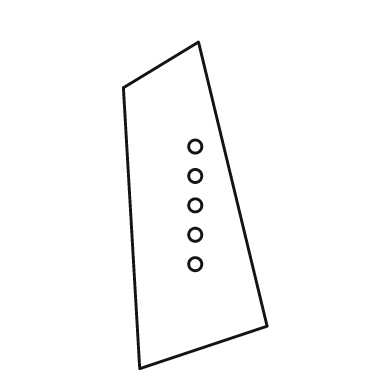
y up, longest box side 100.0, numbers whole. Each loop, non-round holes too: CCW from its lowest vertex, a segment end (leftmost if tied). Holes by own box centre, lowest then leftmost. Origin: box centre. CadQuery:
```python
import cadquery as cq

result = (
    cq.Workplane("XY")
    .moveTo(-17.0, -50.0)
    .lineTo(22.0, -37.0)
    .lineTo(1.0, 50.0)
    .lineTo(-22.0, 36.0)
    .close()
    .moveTo(0.0, -18.0)
    .circle(2.0)
    .moveTo(0.0, -9.0)
    .circle(2.0)
    .moveTo(0.0, 0.0)
    .circle(2.0)
    .moveTo(0.0, 9.0)
    .circle(2.0)
    .moveTo(0.0, 18.0)
    .circle(2.0)
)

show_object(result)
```